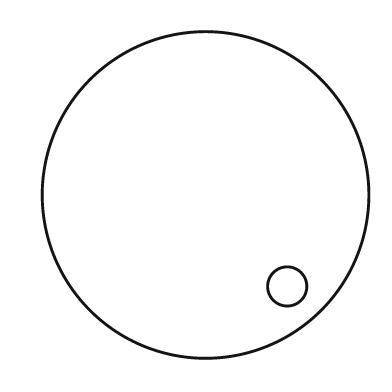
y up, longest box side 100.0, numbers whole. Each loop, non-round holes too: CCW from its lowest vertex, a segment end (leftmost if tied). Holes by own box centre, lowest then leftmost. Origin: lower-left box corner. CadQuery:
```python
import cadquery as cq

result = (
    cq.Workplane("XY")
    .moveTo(50.0, 50.0)
    .circle(50.0)
    .moveTo(75.0, 22.0)
    .circle(6.0)
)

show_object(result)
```